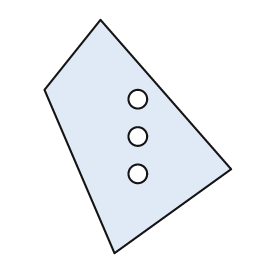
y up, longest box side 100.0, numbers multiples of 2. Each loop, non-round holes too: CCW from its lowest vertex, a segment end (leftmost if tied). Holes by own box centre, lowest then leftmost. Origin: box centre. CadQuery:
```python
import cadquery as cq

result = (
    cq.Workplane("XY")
    .moveTo(-10.0, -50.0)
    .lineTo(40.0, -14.0)
    .lineTo(-16.0, 50.0)
    .lineTo(-40.0, 20.0)
    .close()
    .moveTo(0.0, -16.0)
    .circle(4.0)
    .moveTo(0.0, 0.0)
    .circle(4.0)
    .moveTo(0.0, 16.0)
    .circle(4.0)
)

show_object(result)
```